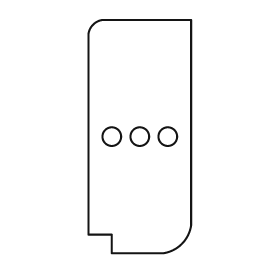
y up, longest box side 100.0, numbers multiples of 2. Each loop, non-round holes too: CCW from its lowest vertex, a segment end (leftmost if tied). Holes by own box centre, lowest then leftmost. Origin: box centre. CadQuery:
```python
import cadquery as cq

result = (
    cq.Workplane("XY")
    .moveTo(-12.0, -50.0)
    .lineTo(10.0, -50.0)
    .threePointArc((18.0, -46.0), (22.0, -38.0))
    .lineTo(22.0, 50.0)
    .lineTo(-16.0, 50.0)
    .threePointArc((-20.0, 48.0), (-22.0, 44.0))
    .lineTo(-22.0, -42.0)
    .lineTo(-12.0, -42.0)
    .close()
    .moveTo(-12.0, 0.0)
    .circle(4.0)
    .moveTo(0.0, 0.0)
    .circle(4.0)
    .moveTo(12.0, 0.0)
    .circle(4.0)
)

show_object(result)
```